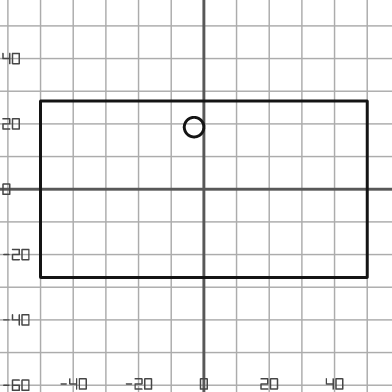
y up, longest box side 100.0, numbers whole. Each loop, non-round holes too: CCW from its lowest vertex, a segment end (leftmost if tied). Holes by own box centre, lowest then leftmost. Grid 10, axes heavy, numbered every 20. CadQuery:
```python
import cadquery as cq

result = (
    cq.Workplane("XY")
    .moveTo(-50.0, -27.0)
    .lineTo(50.0, -27.0)
    .lineTo(50.0, 27.0)
    .lineTo(-50.0, 27.0)
    .close()
    .moveTo(-3.0, 19.0)
    .circle(3.0)
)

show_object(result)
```